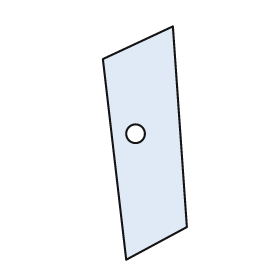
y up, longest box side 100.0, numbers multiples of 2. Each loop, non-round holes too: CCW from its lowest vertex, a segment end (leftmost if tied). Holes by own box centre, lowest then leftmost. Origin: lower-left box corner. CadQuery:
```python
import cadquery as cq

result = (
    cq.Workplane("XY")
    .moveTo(10.0, 0.0)
    .lineTo(36.0, 14.0)
    .lineTo(30.0, 100.0)
    .lineTo(0.0, 86.0)
    .close()
    .moveTo(14.0, 54.0)
    .circle(4.0)
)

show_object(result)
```